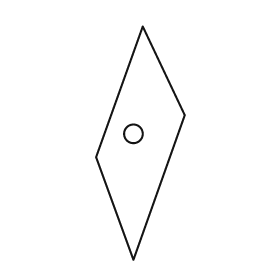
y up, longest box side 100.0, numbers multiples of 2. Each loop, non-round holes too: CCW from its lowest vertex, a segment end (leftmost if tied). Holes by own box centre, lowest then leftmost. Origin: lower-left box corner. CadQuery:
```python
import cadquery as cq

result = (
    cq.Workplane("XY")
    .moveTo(16.0, 0.0)
    .lineTo(38.0, 62.0)
    .lineTo(20.0, 100.0)
    .lineTo(0.0, 44.0)
    .close()
    .moveTo(16.0, 54.0)
    .circle(4.0)
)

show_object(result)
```